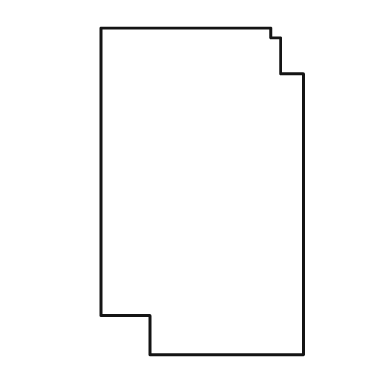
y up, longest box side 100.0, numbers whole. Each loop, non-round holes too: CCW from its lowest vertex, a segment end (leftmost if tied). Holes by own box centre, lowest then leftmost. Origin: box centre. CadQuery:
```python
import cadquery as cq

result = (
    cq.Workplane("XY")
    .moveTo(-16.0, -50.0)
    .lineTo(31.0, -50.0)
    .lineTo(31.0, 36.0)
    .lineTo(24.0, 36.0)
    .lineTo(24.0, 47.0)
    .lineTo(21.0, 47.0)
    .lineTo(21.0, 50.0)
    .lineTo(-31.0, 50.0)
    .lineTo(-31.0, -38.0)
    .lineTo(-16.0, -38.0)
    .close()
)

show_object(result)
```